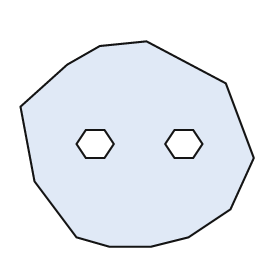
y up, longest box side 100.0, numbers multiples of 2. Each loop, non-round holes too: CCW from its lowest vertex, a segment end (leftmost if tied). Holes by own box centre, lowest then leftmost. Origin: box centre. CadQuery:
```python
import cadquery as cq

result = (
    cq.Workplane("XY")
    .moveTo(-12.0, -44.0)
    .lineTo(6.0, -44.0)
    .lineTo(22.0, -40.0)
    .lineTo(40.0, -28.0)
    .lineTo(50.0, -6.0)
    .lineTo(38.0, 26.0)
    .lineTo(4.0, 44.0)
    .lineTo(-16.0, 42.0)
    .lineTo(-30.0, 34.0)
    .lineTo(-50.0, 16.0)
    .lineTo(-44.0, -16.0)
    .lineTo(-26.0, -40.0)
    .close()
    .moveTo(-22.0, -6.0)
    .lineTo(-14.0, -6.0)
    .lineTo(-10.0, 0.0)
    .lineTo(-14.0, 6.0)
    .lineTo(-22.0, 6.0)
    .lineTo(-26.0, 0.0)
    .close()
    .moveTo(16.0, -6.0)
    .lineTo(24.0, -6.0)
    .lineTo(28.0, 0.0)
    .lineTo(24.0, 6.0)
    .lineTo(16.0, 6.0)
    .lineTo(12.0, 0.0)
    .close()
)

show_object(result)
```